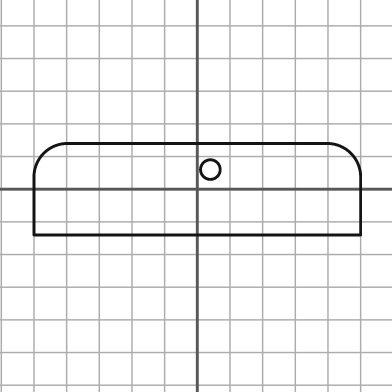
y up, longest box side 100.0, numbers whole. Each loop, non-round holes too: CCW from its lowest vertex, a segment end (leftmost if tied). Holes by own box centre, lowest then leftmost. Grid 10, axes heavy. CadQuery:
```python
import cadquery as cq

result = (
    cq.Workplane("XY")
    .moveTo(-50.0, -14.0)
    .lineTo(50.0, -14.0)
    .lineTo(50.0, 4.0)
    .threePointArc((47.0, 11.0), (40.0, 14.0))
    .lineTo(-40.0, 14.0)
    .threePointArc((-47.0, 11.0), (-50.0, 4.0))
    .close()
    .moveTo(4.0, 6.0)
    .circle(3.0)
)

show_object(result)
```